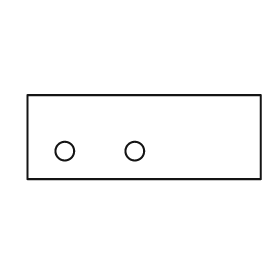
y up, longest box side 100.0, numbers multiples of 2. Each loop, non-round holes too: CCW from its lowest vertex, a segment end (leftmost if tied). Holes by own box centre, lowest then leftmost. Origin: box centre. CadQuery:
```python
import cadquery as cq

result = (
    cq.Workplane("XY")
    .moveTo(-50.0, -18.0)
    .lineTo(50.0, -18.0)
    .lineTo(50.0, 18.0)
    .lineTo(-50.0, 18.0)
    .close()
    .moveTo(-34.0, -6.0)
    .circle(4.0)
    .moveTo(-4.0, -6.0)
    .circle(4.0)
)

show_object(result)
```